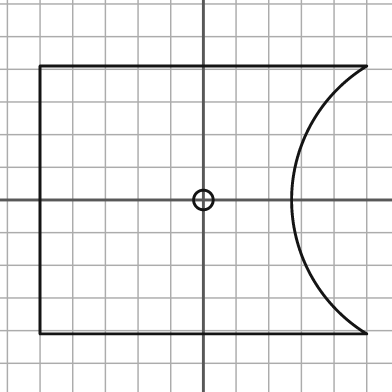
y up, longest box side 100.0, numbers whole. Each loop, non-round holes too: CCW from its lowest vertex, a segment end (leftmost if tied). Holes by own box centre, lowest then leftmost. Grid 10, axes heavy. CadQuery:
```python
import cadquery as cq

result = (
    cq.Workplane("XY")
    .moveTo(-50.0, -41.0)
    .lineTo(50.0, -41.0)
    .threePointArc((27.0, 0.0), (50.0, 41.0))
    .lineTo(-50.0, 41.0)
    .close()
    .moveTo(0.0, 0.0)
    .circle(3.0)
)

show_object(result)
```